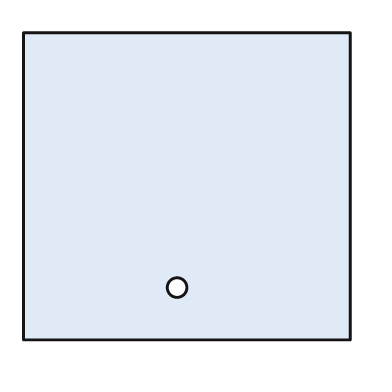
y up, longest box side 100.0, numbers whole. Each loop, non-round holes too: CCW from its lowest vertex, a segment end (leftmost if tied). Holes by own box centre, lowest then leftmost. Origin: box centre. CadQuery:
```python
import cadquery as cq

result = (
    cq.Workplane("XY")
    .moveTo(-50.0, -47.0)
    .lineTo(50.0, -47.0)
    .lineTo(50.0, 47.0)
    .lineTo(-50.0, 47.0)
    .close()
    .moveTo(-3.0, -31.0)
    .circle(3.0)
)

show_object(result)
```